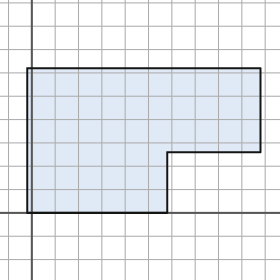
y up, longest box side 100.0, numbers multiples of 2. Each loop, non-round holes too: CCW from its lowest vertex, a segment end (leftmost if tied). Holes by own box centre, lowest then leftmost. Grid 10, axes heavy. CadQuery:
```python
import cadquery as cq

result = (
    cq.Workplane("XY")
    .moveTo(-2.0, 0.0)
    .lineTo(58.0, 0.0)
    .lineTo(58.0, 26.0)
    .lineTo(98.0, 26.0)
    .lineTo(98.0, 62.0)
    .lineTo(-2.0, 62.0)
    .close()
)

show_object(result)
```